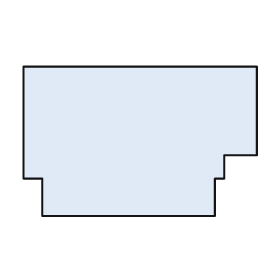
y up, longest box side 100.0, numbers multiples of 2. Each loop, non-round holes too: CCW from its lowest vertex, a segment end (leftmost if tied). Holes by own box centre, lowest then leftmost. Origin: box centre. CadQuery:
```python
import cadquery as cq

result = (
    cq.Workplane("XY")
    .moveTo(-42.0, -32.0)
    .lineTo(32.0, -32.0)
    .lineTo(32.0, -16.0)
    .lineTo(36.0, -16.0)
    .lineTo(36.0, -6.0)
    .lineTo(50.0, -6.0)
    .lineTo(50.0, 32.0)
    .lineTo(-50.0, 32.0)
    .lineTo(-50.0, -16.0)
    .lineTo(-42.0, -16.0)
    .close()
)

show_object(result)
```